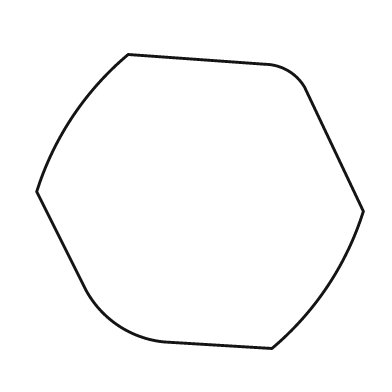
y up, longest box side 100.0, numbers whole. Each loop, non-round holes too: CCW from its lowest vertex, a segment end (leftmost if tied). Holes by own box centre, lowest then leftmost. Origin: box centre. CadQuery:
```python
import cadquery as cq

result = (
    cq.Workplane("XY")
    .moveTo(22.0, -45.0)
    .threePointArc((39.0, -26.0), (50.0, -3.0))
    .lineTo(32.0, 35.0)
    .threePointArc((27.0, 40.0), (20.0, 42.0))
    .lineTo(-22.0, 45.0)
    .threePointArc((-39.0, 26.0), (-50.0, 3.0))
    .lineTo(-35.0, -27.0)
    .threePointArc((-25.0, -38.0), (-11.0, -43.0))
    .close()
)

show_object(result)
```